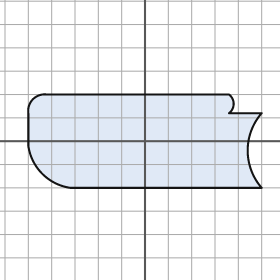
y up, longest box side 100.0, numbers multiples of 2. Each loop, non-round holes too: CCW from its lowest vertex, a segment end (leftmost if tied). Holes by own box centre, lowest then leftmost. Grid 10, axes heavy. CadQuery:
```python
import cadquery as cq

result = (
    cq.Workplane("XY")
    .moveTo(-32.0, -20.0)
    .lineTo(50.0, -20.0)
    .threePointArc((44.0, -4.0), (50.0, 12.0))
    .lineTo(36.0, 12.0)
    .threePointArc((38.0, 16.0), (36.0, 20.0))
    .lineTo(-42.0, 20.0)
    .threePointArc((-48.0, 18.0), (-50.0, 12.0))
    .lineTo(-50.0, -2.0)
    .threePointArc((-44.0, -14.0), (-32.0, -20.0))
    .close()
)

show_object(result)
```